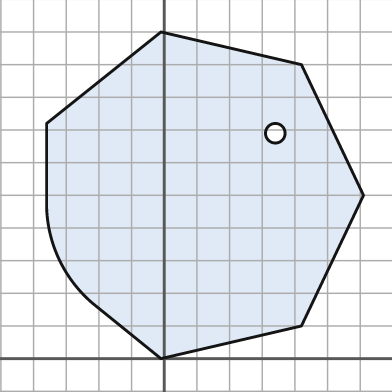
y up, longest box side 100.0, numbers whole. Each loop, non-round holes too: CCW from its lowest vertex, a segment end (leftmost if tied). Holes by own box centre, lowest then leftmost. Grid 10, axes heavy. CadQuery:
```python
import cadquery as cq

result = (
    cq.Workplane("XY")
    .moveTo(-1.0, 0.0)
    .lineTo(42.0, 10.0)
    .lineTo(61.0, 50.0)
    .lineTo(42.0, 90.0)
    .lineTo(-1.0, 100.0)
    .lineTo(-36.0, 72.0)
    .lineTo(-36.0, 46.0)
    .threePointArc((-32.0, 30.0), (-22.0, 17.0))
    .close()
    .moveTo(34.0, 69.0)
    .circle(3.0)
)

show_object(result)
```